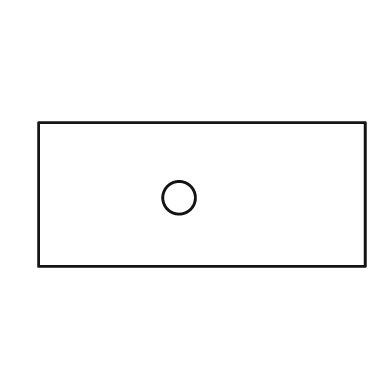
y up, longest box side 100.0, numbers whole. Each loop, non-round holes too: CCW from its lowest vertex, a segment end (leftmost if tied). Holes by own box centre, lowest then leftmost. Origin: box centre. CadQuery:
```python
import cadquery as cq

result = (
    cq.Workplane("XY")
    .moveTo(-50.0, -22.0)
    .lineTo(50.0, -22.0)
    .lineTo(50.0, 22.0)
    .lineTo(-50.0, 22.0)
    .close()
    .moveTo(-7.0, -1.0)
    .circle(5.0)
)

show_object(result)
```